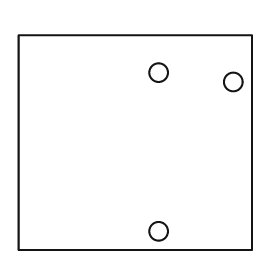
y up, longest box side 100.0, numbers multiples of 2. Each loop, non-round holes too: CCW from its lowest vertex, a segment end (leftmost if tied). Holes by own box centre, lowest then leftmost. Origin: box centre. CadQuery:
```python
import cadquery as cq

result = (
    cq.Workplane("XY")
    .moveTo(-50.0, -46.0)
    .lineTo(50.0, -46.0)
    .lineTo(50.0, 46.0)
    .lineTo(-50.0, 46.0)
    .close()
    .moveTo(10.0, -38.0)
    .circle(4.0)
    .moveTo(42.0, 26.0)
    .circle(4.0)
    .moveTo(10.0, 30.0)
    .circle(4.0)
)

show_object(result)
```